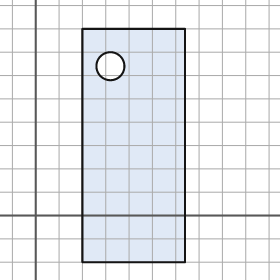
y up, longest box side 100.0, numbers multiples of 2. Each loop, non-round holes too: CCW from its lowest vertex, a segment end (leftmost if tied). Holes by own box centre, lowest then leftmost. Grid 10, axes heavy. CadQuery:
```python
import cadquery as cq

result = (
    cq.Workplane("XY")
    .moveTo(20.0, -20.0)
    .lineTo(64.0, -20.0)
    .lineTo(64.0, 80.0)
    .lineTo(20.0, 80.0)
    .close()
    .moveTo(32.0, 64.0)
    .circle(6.0)
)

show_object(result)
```